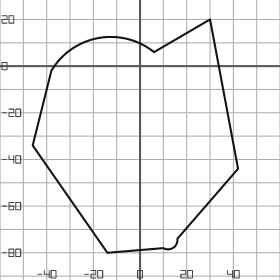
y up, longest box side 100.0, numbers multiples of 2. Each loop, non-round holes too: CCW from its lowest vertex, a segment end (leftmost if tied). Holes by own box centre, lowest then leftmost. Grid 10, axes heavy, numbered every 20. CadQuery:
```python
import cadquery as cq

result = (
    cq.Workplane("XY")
    .moveTo(-14.0, -80.0)
    .lineTo(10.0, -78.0)
    .threePointArc((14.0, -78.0), (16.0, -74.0))
    .lineTo(42.0, -44.0)
    .lineTo(30.0, 20.0)
    .lineTo(6.0, 6.0)
    .threePointArc((-18.0, 12.0), (-38.0, -2.0))
    .lineTo(-46.0, -34.0)
    .close()
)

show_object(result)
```